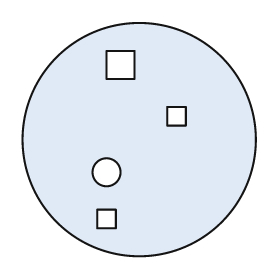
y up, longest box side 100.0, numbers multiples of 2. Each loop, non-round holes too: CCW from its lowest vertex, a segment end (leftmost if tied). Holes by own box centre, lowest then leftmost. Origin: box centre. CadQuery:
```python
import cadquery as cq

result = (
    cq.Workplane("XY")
    .moveTo(0.0, 0.0)
    .circle(50.0)
    .moveTo(-18.0, -38.0)
    .lineTo(-10.0, -38.0)
    .lineTo(-10.0, -30.0)
    .lineTo(-18.0, -30.0)
    .close()
    .moveTo(-14.0, -14.0)
    .circle(6.0)
    .moveTo(12.0, 6.0)
    .lineTo(20.0, 6.0)
    .lineTo(20.0, 14.0)
    .lineTo(12.0, 14.0)
    .close()
    .moveTo(-14.0, 26.0)
    .lineTo(-2.0, 26.0)
    .lineTo(-2.0, 38.0)
    .lineTo(-14.0, 38.0)
    .close()
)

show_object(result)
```